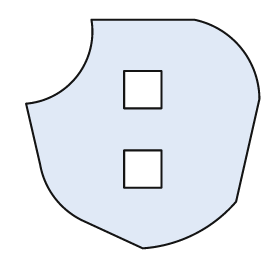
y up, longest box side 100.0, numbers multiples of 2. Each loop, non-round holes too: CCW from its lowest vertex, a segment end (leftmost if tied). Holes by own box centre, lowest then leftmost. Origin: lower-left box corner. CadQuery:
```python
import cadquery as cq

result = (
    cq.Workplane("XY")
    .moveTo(50.0, 0.0)
    .threePointArc((72.0, 6.0), (90.0, 20.0))
    .lineTo(100.0, 64.0)
    .threePointArc((92.0, 86.0), (72.0, 98.0))
    .lineTo(28.0, 98.0)
    .threePointArc((22.0, 74.0), (0.0, 62.0))
    .lineTo(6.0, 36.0)
    .threePointArc((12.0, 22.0), (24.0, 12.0))
    .close()
    .moveTo(42.0, 26.0)
    .lineTo(58.0, 26.0)
    .lineTo(58.0, 42.0)
    .lineTo(42.0, 42.0)
    .close()
    .moveTo(42.0, 60.0)
    .lineTo(58.0, 60.0)
    .lineTo(58.0, 76.0)
    .lineTo(42.0, 76.0)
    .close()
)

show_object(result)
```